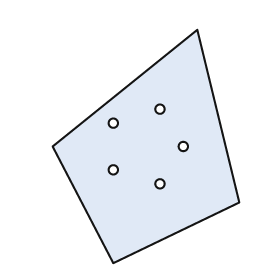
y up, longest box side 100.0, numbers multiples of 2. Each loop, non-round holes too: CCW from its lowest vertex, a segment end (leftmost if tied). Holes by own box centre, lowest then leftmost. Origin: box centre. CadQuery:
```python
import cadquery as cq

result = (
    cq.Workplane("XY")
    .moveTo(-14.0, -50.0)
    .lineTo(40.0, -24.0)
    .lineTo(22.0, 50.0)
    .lineTo(-40.0, 0.0)
    .close()
    .moveTo(6.0, -16.0)
    .circle(2.0)
    .moveTo(-14.0, -10.0)
    .circle(2.0)
    .moveTo(16.0, 0.0)
    .circle(2.0)
    .moveTo(-14.0, 10.0)
    .circle(2.0)
    .moveTo(6.0, 16.0)
    .circle(2.0)
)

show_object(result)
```